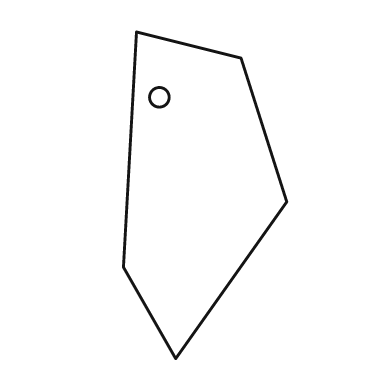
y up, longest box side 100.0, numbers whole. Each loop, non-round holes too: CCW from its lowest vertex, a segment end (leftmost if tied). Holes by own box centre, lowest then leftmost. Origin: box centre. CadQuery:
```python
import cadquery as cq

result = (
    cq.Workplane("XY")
    .moveTo(-9.0, -50.0)
    .lineTo(25.0, -2.0)
    .lineTo(11.0, 42.0)
    .lineTo(-21.0, 50.0)
    .lineTo(-25.0, -22.0)
    .close()
    .moveTo(-14.0, 30.0)
    .circle(3.0)
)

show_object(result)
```